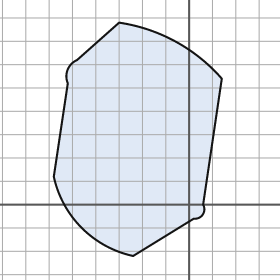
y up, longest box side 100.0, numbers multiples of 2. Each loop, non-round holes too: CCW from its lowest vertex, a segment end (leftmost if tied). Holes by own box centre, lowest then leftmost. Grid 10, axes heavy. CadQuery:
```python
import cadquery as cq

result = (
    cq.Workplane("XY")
    .moveTo(-24.0, -22.0)
    .lineTo(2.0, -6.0)
    .threePointArc((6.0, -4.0), (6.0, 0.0))
    .lineTo(14.0, 54.0)
    .threePointArc((-6.0, 70.0), (-30.0, 78.0))
    .lineTo(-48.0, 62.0)
    .threePointArc((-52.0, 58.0), (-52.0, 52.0))
    .lineTo(-58.0, 12.0)
    .threePointArc((-46.0, -10.0), (-24.0, -22.0))
    .close()
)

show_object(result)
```